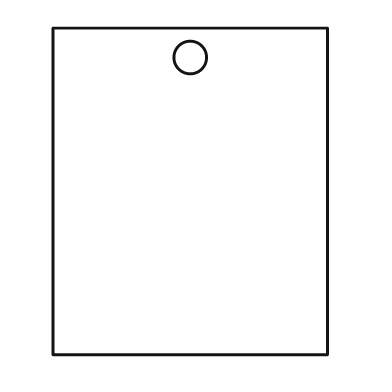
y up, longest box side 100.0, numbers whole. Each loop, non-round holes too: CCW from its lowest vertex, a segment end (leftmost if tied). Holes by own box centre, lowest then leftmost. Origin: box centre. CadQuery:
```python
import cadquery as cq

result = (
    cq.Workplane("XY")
    .moveTo(-42.0, -50.0)
    .lineTo(42.0, -50.0)
    .lineTo(42.0, 50.0)
    .lineTo(-42.0, 50.0)
    .close()
    .moveTo(0.0, 41.0)
    .circle(5.0)
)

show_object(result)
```